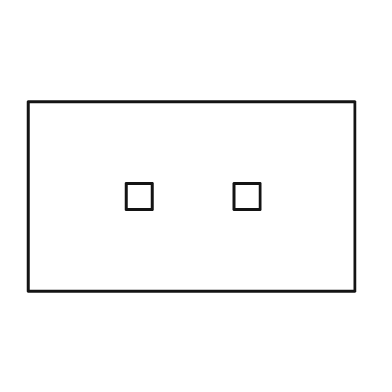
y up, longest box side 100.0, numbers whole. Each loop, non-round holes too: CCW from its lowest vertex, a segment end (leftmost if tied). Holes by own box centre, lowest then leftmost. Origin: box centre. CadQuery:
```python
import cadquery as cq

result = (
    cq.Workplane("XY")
    .moveTo(-50.0, -29.0)
    .lineTo(50.0, -29.0)
    .lineTo(50.0, 29.0)
    .lineTo(-50.0, 29.0)
    .close()
    .moveTo(-20.0, -4.0)
    .lineTo(-12.0, -4.0)
    .lineTo(-12.0, 4.0)
    .lineTo(-20.0, 4.0)
    .close()
    .moveTo(13.0, -4.0)
    .lineTo(21.0, -4.0)
    .lineTo(21.0, 4.0)
    .lineTo(13.0, 4.0)
    .close()
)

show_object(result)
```